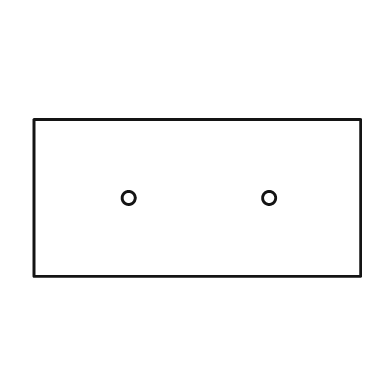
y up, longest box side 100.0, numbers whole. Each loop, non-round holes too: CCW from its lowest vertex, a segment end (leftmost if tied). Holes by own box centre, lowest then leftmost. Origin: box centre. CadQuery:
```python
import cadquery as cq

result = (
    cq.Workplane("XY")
    .moveTo(-50.0, -24.0)
    .lineTo(50.0, -24.0)
    .lineTo(50.0, 24.0)
    .lineTo(-50.0, 24.0)
    .close()
    .moveTo(-21.0, 0.0)
    .circle(2.0)
    .moveTo(22.0, 0.0)
    .circle(2.0)
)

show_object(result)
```